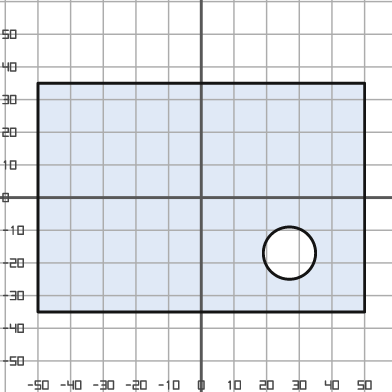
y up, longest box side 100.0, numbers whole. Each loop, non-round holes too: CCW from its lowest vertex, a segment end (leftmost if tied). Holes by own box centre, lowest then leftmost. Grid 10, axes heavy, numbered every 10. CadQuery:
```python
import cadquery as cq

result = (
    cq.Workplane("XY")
    .moveTo(-50.0, -35.0)
    .lineTo(50.0, -35.0)
    .lineTo(50.0, 35.0)
    .lineTo(-50.0, 35.0)
    .close()
    .moveTo(27.0, -17.0)
    .circle(8.0)
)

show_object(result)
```